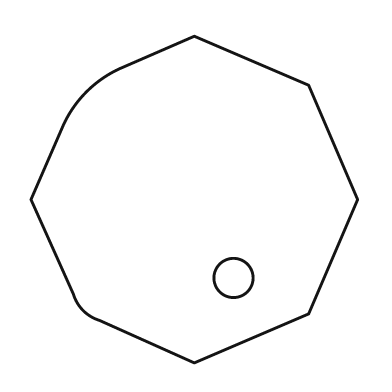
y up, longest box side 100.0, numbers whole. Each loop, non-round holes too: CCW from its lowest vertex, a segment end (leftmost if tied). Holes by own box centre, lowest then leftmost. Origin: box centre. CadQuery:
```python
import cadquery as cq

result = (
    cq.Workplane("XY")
    .moveTo(0.0, -50.0)
    .lineTo(35.0, -35.0)
    .lineTo(50.0, 0.0)
    .lineTo(35.0, 35.0)
    .lineTo(0.0, 50.0)
    .lineTo(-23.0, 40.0)
    .threePointArc((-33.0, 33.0), (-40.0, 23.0))
    .lineTo(-50.0, 0.0)
    .lineTo(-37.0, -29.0)
    .threePointArc((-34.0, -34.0), (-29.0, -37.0))
    .close()
    .moveTo(12.0, -24.0)
    .circle(6.0)
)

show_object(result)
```